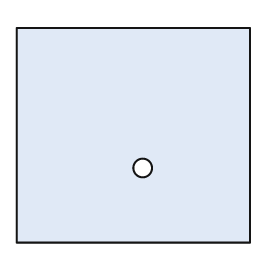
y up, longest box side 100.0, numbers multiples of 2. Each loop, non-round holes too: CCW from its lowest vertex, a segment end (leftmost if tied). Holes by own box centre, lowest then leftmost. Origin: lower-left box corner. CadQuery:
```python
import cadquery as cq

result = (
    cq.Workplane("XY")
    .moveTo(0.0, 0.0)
    .lineTo(100.0, 0.0)
    .lineTo(100.0, 92.0)
    .lineTo(0.0, 92.0)
    .close()
    .moveTo(54.0, 32.0)
    .circle(4.0)
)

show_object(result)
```